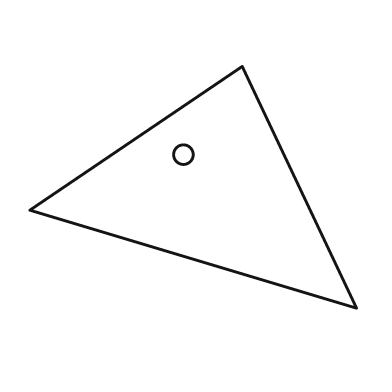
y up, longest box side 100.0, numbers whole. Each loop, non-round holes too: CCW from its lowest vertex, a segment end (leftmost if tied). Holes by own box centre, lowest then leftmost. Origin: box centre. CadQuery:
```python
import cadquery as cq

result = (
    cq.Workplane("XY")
    .moveTo(50.0, -37.0)
    .lineTo(15.0, 37.0)
    .lineTo(-50.0, -7.0)
    .close()
    .moveTo(-3.0, 10.0)
    .circle(3.0)
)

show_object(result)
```